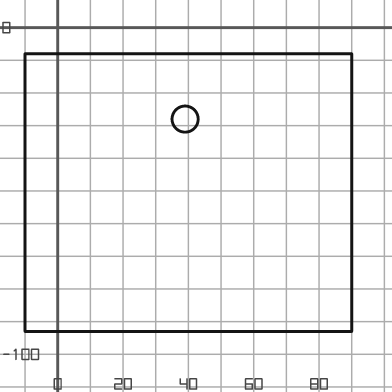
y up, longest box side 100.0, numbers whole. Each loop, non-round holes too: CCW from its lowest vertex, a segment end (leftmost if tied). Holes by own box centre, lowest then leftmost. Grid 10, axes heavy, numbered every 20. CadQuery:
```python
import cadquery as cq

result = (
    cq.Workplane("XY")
    .moveTo(-10.0, -93.0)
    .lineTo(90.0, -93.0)
    .lineTo(90.0, -8.0)
    .lineTo(-10.0, -8.0)
    .close()
    .moveTo(39.0, -28.0)
    .circle(4.0)
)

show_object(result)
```